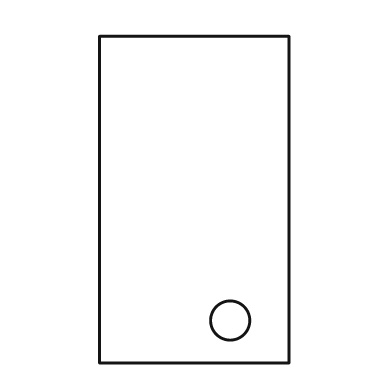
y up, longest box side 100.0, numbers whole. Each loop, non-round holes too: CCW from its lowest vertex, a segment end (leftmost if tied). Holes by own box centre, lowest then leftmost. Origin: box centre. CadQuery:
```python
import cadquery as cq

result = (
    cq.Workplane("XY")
    .moveTo(-29.0, -50.0)
    .lineTo(29.0, -50.0)
    .lineTo(29.0, 50.0)
    .lineTo(-29.0, 50.0)
    .close()
    .moveTo(11.0, -37.0)
    .circle(6.0)
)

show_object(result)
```